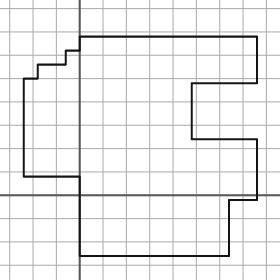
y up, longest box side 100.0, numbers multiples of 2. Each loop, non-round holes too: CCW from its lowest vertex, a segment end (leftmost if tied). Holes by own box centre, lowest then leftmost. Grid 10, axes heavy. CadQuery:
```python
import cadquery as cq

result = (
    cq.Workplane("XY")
    .moveTo(0.0, -26.0)
    .lineTo(64.0, -26.0)
    .lineTo(64.0, -2.0)
    .lineTo(76.0, -2.0)
    .lineTo(76.0, 24.0)
    .lineTo(48.0, 24.0)
    .lineTo(48.0, 48.0)
    .lineTo(76.0, 48.0)
    .lineTo(76.0, 68.0)
    .lineTo(0.0, 68.0)
    .lineTo(0.0, 62.0)
    .lineTo(-6.0, 62.0)
    .lineTo(-6.0, 56.0)
    .lineTo(-18.0, 56.0)
    .lineTo(-18.0, 50.0)
    .lineTo(-24.0, 50.0)
    .lineTo(-24.0, 8.0)
    .lineTo(0.0, 8.0)
    .close()
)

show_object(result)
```